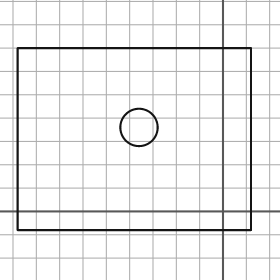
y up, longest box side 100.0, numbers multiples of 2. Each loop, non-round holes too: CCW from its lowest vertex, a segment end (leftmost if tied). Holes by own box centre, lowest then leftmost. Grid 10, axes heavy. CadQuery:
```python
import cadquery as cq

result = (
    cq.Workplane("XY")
    .moveTo(-88.0, -8.0)
    .lineTo(12.0, -8.0)
    .lineTo(12.0, 70.0)
    .lineTo(-88.0, 70.0)
    .close()
    .moveTo(-36.0, 36.0)
    .circle(8.0)
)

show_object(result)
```